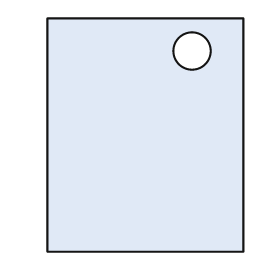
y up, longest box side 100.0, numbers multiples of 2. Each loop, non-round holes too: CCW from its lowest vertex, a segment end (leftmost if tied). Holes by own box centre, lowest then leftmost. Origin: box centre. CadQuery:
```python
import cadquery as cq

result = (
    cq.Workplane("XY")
    .moveTo(-42.0, -50.0)
    .lineTo(42.0, -50.0)
    .lineTo(42.0, 50.0)
    .lineTo(-42.0, 50.0)
    .close()
    .moveTo(20.0, 36.0)
    .circle(8.0)
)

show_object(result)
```